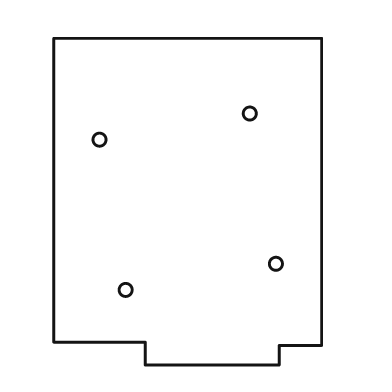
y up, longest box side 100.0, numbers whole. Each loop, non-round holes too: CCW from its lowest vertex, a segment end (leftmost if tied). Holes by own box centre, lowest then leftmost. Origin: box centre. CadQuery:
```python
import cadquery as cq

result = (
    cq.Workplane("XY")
    .moveTo(-13.0, -50.0)
    .lineTo(28.0, -50.0)
    .lineTo(28.0, -44.0)
    .lineTo(41.0, -44.0)
    .lineTo(41.0, 50.0)
    .lineTo(-41.0, 50.0)
    .lineTo(-41.0, -43.0)
    .lineTo(-13.0, -43.0)
    .close()
    .moveTo(-19.0, -27.0)
    .circle(2.0)
    .moveTo(27.0, -19.0)
    .circle(2.0)
    .moveTo(-27.0, 19.0)
    .circle(2.0)
    .moveTo(19.0, 27.0)
    .circle(2.0)
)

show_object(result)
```